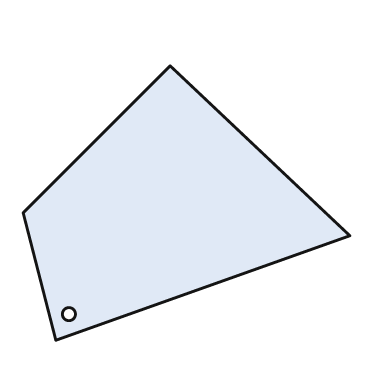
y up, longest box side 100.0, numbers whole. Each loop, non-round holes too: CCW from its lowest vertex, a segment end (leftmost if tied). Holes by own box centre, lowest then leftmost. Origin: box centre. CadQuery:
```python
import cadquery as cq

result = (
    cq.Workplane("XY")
    .moveTo(-40.0, -42.0)
    .lineTo(50.0, -10.0)
    .lineTo(-5.0, 42.0)
    .lineTo(-50.0, -3.0)
    .close()
    .moveTo(-36.0, -34.0)
    .circle(2.0)
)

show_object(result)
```